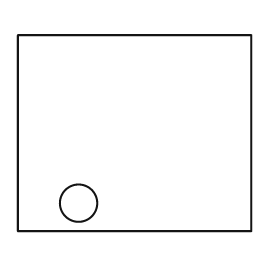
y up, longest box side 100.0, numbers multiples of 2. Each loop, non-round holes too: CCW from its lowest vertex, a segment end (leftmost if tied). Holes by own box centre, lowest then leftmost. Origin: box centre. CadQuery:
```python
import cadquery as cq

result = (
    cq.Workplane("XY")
    .moveTo(-50.0, -42.0)
    .lineTo(50.0, -42.0)
    .lineTo(50.0, 42.0)
    .lineTo(-50.0, 42.0)
    .close()
    .moveTo(-24.0, -30.0)
    .circle(8.0)
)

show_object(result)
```